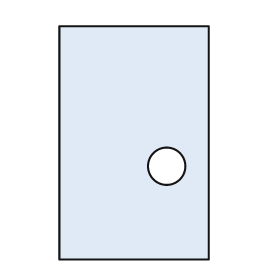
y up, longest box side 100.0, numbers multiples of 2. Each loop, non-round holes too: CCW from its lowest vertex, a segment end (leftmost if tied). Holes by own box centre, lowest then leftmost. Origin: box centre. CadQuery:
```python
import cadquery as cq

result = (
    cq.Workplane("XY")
    .moveTo(-32.0, -50.0)
    .lineTo(32.0, -50.0)
    .lineTo(32.0, 50.0)
    .lineTo(-32.0, 50.0)
    .close()
    .moveTo(14.0, -10.0)
    .circle(8.0)
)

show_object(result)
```